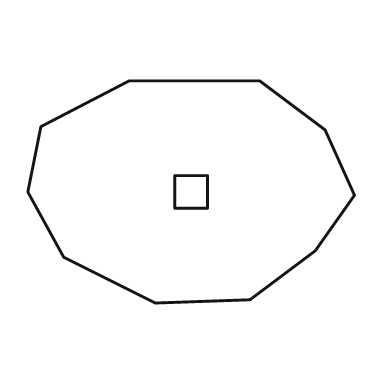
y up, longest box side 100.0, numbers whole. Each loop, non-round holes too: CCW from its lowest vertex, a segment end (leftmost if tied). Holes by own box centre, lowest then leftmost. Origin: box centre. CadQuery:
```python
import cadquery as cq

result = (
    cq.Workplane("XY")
    .moveTo(-11.0, -34.0)
    .lineTo(18.0, -33.0)
    .lineTo(38.0, -18.0)
    .lineTo(50.0, -1.0)
    .lineTo(41.0, 19.0)
    .lineTo(21.0, 34.0)
    .lineTo(-19.0, 34.0)
    .lineTo(-46.0, 20.0)
    .lineTo(-50.0, 0.0)
    .lineTo(-39.0, -20.0)
    .close()
    .moveTo(-5.0, -5.0)
    .lineTo(5.0, -5.0)
    .lineTo(5.0, 5.0)
    .lineTo(-5.0, 5.0)
    .close()
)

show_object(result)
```